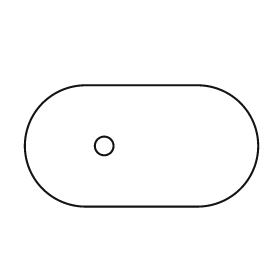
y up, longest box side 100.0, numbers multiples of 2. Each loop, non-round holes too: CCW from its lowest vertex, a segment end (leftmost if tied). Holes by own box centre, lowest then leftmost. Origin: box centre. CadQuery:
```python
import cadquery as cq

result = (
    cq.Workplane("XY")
    .moveTo(-24.0, -26.0)
    .lineTo(24.0, -26.0)
    .threePointArc((50.0, 0.0), (24.0, 26.0))
    .lineTo(-24.0, 26.0)
    .threePointArc((-50.0, 0.0), (-24.0, -26.0))
    .close()
    .moveTo(-16.0, 0.0)
    .circle(4.0)
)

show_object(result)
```